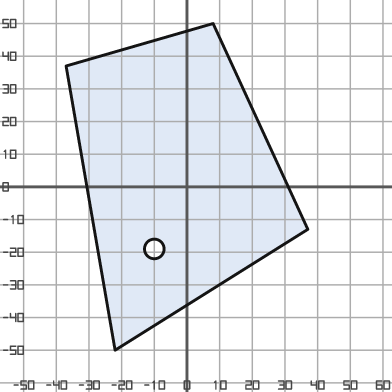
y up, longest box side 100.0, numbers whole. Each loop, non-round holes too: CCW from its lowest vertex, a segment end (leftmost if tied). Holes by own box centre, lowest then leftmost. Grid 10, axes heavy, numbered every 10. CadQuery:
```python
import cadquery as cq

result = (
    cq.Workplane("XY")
    .moveTo(-22.0, -50.0)
    .lineTo(37.0, -13.0)
    .lineTo(8.0, 50.0)
    .lineTo(-37.0, 37.0)
    .close()
    .moveTo(-10.0, -19.0)
    .circle(3.0)
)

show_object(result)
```